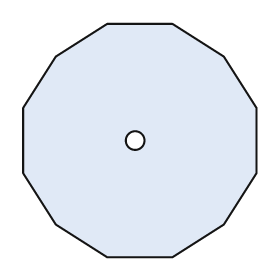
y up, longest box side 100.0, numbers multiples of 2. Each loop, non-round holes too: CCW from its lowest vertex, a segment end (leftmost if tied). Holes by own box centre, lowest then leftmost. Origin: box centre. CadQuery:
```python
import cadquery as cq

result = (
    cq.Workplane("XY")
    .moveTo(-14.0, -50.0)
    .lineTo(14.0, -50.0)
    .lineTo(36.0, -36.0)
    .lineTo(50.0, -14.0)
    .lineTo(50.0, 14.0)
    .lineTo(36.0, 36.0)
    .lineTo(14.0, 50.0)
    .lineTo(-14.0, 50.0)
    .lineTo(-36.0, 36.0)
    .lineTo(-50.0, 14.0)
    .lineTo(-50.0, -14.0)
    .lineTo(-36.0, -36.0)
    .close()
    .moveTo(-2.0, 0.0)
    .circle(4.0)
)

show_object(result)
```